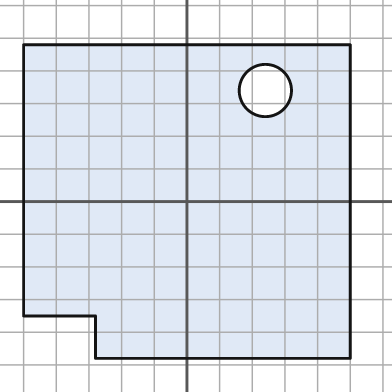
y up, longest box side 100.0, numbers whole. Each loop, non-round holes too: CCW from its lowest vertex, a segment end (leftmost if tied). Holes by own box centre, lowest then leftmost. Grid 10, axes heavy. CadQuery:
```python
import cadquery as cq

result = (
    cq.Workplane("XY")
    .moveTo(-28.0, -48.0)
    .lineTo(50.0, -48.0)
    .lineTo(50.0, 48.0)
    .lineTo(-50.0, 48.0)
    .lineTo(-50.0, -35.0)
    .lineTo(-28.0, -35.0)
    .close()
    .moveTo(24.0, 34.0)
    .circle(8.0)
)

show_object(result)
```